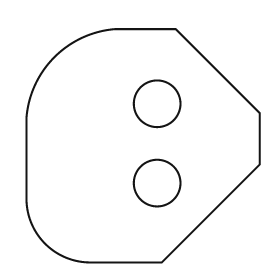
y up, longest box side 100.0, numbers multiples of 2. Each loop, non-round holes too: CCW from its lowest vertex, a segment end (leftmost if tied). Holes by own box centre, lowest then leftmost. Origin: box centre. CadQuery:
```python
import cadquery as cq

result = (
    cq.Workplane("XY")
    .moveTo(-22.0, -50.0)
    .lineTo(8.0, -50.0)
    .lineTo(50.0, -8.0)
    .lineTo(50.0, 14.0)
    .lineTo(14.0, 50.0)
    .lineTo(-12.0, 50.0)
    .threePointArc((-38.0, 38.0), (-50.0, 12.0))
    .lineTo(-50.0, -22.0)
    .threePointArc((-42.0, -42.0), (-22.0, -50.0))
    .close()
    .moveTo(6.0, -16.0)
    .circle(10.0)
    .moveTo(6.0, 18.0)
    .circle(10.0)
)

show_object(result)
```